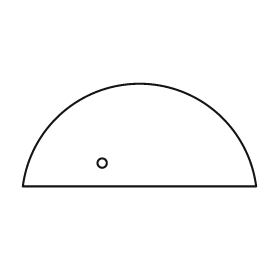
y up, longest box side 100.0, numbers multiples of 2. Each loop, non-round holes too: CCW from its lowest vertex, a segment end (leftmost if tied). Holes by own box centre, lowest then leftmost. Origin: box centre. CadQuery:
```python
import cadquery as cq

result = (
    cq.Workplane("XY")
    .moveTo(-50.0, -22.0)
    .lineTo(50.0, -22.0)
    .threePointArc((0.0, 22.0), (-50.0, -22.0))
    .close()
    .moveTo(-16.0, -12.0)
    .circle(2.0)
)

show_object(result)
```